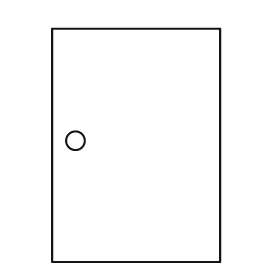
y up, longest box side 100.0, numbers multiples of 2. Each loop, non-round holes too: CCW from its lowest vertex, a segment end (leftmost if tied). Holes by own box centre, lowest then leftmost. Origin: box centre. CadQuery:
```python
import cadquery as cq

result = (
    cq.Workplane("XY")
    .moveTo(-36.0, -50.0)
    .lineTo(36.0, -50.0)
    .lineTo(36.0, 50.0)
    .lineTo(-36.0, 50.0)
    .close()
    .moveTo(-26.0, 2.0)
    .circle(4.0)
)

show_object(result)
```